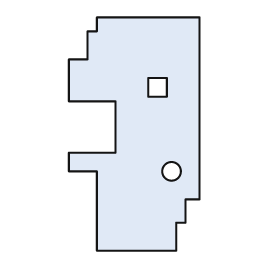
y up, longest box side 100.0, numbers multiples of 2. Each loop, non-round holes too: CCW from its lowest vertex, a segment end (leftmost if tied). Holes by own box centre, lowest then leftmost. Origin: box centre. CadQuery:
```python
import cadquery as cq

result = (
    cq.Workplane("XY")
    .moveTo(-16.0, -50.0)
    .lineTo(18.0, -50.0)
    .lineTo(18.0, -38.0)
    .lineTo(22.0, -38.0)
    .lineTo(22.0, -28.0)
    .lineTo(28.0, -28.0)
    .lineTo(28.0, 50.0)
    .lineTo(-16.0, 50.0)
    .lineTo(-16.0, 44.0)
    .lineTo(-20.0, 44.0)
    .lineTo(-20.0, 32.0)
    .lineTo(-28.0, 32.0)
    .lineTo(-28.0, 14.0)
    .lineTo(-8.0, 14.0)
    .lineTo(-8.0, -8.0)
    .lineTo(-28.0, -8.0)
    .lineTo(-28.0, -16.0)
    .lineTo(-16.0, -16.0)
    .close()
    .moveTo(16.0, -16.0)
    .circle(4.0)
    .moveTo(6.0, 16.0)
    .lineTo(14.0, 16.0)
    .lineTo(14.0, 24.0)
    .lineTo(6.0, 24.0)
    .close()
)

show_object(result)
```